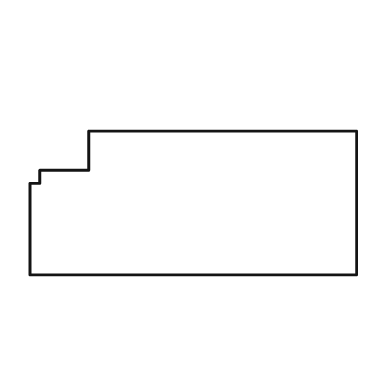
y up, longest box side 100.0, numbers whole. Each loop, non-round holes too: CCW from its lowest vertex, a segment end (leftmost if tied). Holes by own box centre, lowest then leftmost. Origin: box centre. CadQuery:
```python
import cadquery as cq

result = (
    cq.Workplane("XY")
    .moveTo(-50.0, -22.0)
    .lineTo(50.0, -22.0)
    .lineTo(50.0, 22.0)
    .lineTo(-32.0, 22.0)
    .lineTo(-32.0, 10.0)
    .lineTo(-47.0, 10.0)
    .lineTo(-47.0, 6.0)
    .lineTo(-50.0, 6.0)
    .close()
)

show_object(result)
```